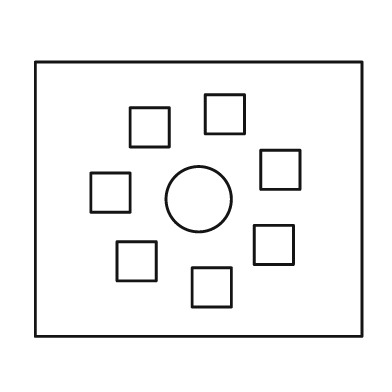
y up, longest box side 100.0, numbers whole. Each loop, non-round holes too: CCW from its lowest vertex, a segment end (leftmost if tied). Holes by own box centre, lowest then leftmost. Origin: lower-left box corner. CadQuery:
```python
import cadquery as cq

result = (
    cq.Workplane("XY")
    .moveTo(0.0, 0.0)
    .lineTo(100.0, 0.0)
    .lineTo(100.0, 84.0)
    .lineTo(0.0, 84.0)
    .close()
    .moveTo(48.0, 9.0)
    .lineTo(60.0, 9.0)
    .lineTo(60.0, 21.0)
    .lineTo(48.0, 21.0)
    .close()
    .moveTo(25.0, 17.0)
    .lineTo(37.0, 17.0)
    .lineTo(37.0, 29.0)
    .lineTo(25.0, 29.0)
    .close()
    .moveTo(67.0, 22.0)
    .lineTo(79.0, 22.0)
    .lineTo(79.0, 34.0)
    .lineTo(67.0, 34.0)
    .close()
    .moveTo(50.0, 42.0)
    .circle(10.0)
    .moveTo(17.0, 38.0)
    .lineTo(29.0, 38.0)
    .lineTo(29.0, 50.0)
    .lineTo(17.0, 50.0)
    .close()
    .moveTo(69.0, 45.0)
    .lineTo(81.0, 45.0)
    .lineTo(81.0, 57.0)
    .lineTo(69.0, 57.0)
    .close()
    .moveTo(29.0, 58.0)
    .lineTo(41.0, 58.0)
    .lineTo(41.0, 70.0)
    .lineTo(29.0, 70.0)
    .close()
    .moveTo(52.0, 62.0)
    .lineTo(64.0, 62.0)
    .lineTo(64.0, 74.0)
    .lineTo(52.0, 74.0)
    .close()
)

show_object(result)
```